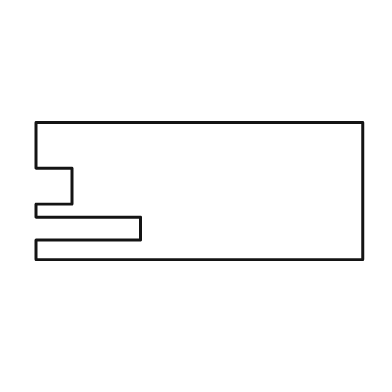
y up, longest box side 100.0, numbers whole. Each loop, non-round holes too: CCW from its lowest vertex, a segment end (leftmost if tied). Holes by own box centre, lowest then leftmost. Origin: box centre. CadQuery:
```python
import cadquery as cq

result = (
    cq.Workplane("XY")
    .moveTo(-50.0, -21.0)
    .lineTo(50.0, -21.0)
    .lineTo(50.0, 21.0)
    .lineTo(-50.0, 21.0)
    .lineTo(-50.0, 7.0)
    .lineTo(-39.0, 7.0)
    .lineTo(-39.0, -4.0)
    .lineTo(-50.0, -4.0)
    .lineTo(-50.0, -8.0)
    .lineTo(-18.0, -8.0)
    .lineTo(-18.0, -15.0)
    .lineTo(-50.0, -15.0)
    .close()
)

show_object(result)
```